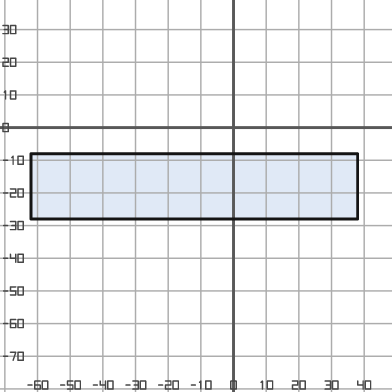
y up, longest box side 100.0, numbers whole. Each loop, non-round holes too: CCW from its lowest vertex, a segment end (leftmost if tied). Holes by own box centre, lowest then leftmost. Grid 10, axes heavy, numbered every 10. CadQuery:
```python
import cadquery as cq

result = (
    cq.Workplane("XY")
    .moveTo(-62.0, -28.0)
    .lineTo(38.0, -28.0)
    .lineTo(38.0, -8.0)
    .lineTo(-62.0, -8.0)
    .close()
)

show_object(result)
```